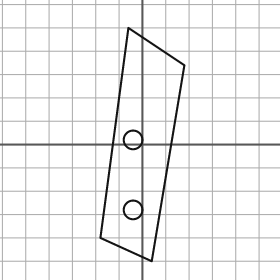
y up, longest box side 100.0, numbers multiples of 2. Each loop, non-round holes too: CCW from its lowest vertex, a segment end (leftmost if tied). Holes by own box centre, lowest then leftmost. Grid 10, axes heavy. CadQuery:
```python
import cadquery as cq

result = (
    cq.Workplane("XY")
    .moveTo(4.0, -50.0)
    .lineTo(18.0, 34.0)
    .lineTo(-6.0, 50.0)
    .lineTo(-18.0, -40.0)
    .close()
    .moveTo(-4.0, -28.0)
    .circle(4.0)
    .moveTo(-4.0, 2.0)
    .circle(4.0)
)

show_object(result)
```